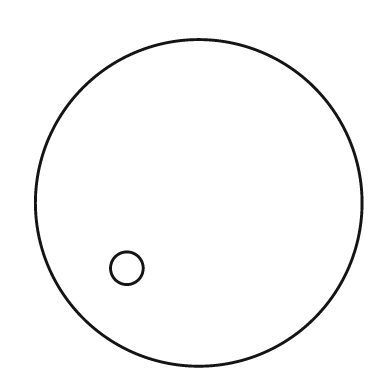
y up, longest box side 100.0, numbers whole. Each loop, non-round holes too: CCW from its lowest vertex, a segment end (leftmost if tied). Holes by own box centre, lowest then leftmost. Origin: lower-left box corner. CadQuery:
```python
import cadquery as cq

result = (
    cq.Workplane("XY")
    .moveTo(50.0, 50.0)
    .circle(50.0)
    .moveTo(28.0, 30.0)
    .circle(5.0)
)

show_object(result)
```